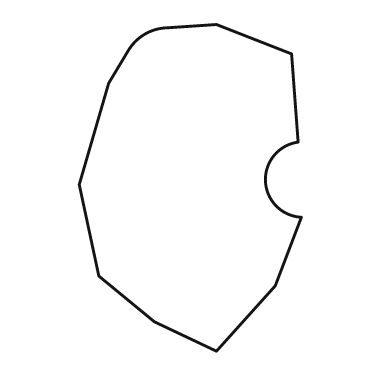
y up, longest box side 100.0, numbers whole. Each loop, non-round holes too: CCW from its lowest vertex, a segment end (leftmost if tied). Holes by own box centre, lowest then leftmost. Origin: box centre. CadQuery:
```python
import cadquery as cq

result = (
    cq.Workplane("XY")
    .moveTo(8.0, -50.0)
    .lineTo(26.0, -30.0)
    .lineTo(34.0, -9.0)
    .threePointArc((23.0, 2.0), (33.0, 14.0))
    .lineTo(31.0, 41.0)
    .lineTo(8.0, 50.0)
    .lineTo(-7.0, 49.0)
    .threePointArc((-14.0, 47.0), (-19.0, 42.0))
    .lineTo(-25.0, 32.0)
    .lineTo(-34.0, 1.0)
    .lineTo(-28.0, -27.0)
    .lineTo(-11.0, -41.0)
    .close()
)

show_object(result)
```